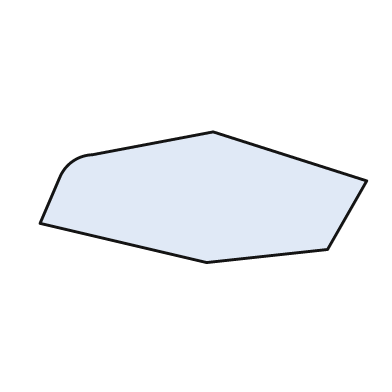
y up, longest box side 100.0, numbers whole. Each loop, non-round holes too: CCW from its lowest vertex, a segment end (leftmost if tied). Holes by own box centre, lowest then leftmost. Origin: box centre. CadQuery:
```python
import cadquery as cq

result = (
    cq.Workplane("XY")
    .moveTo(1.0, -20.0)
    .lineTo(38.0, -16.0)
    .lineTo(50.0, 5.0)
    .lineTo(3.0, 20.0)
    .lineTo(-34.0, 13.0)
    .threePointArc((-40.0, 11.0), (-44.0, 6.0))
    .lineTo(-50.0, -8.0)
    .close()
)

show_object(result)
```